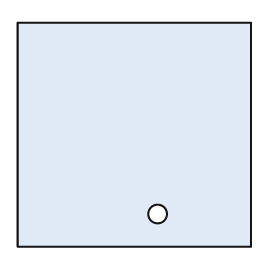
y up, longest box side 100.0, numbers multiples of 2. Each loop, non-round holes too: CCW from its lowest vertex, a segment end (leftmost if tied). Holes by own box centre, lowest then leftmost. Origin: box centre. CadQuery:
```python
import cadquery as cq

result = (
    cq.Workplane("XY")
    .moveTo(-50.0, -48.0)
    .lineTo(50.0, -48.0)
    .lineTo(50.0, 48.0)
    .lineTo(-50.0, 48.0)
    .close()
    .moveTo(10.0, -34.0)
    .circle(4.0)
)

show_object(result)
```